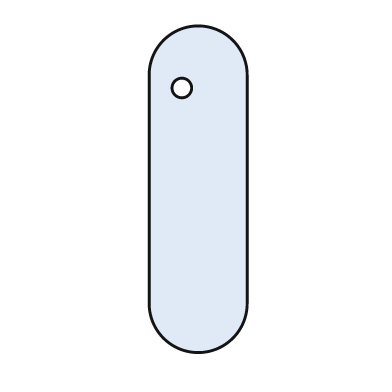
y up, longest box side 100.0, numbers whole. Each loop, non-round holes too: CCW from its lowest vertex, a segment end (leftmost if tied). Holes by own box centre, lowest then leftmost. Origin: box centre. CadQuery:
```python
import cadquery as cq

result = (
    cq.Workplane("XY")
    .moveTo(-15.0, -35.0)
    .threePointArc((0.0, -50.0), (15.0, -35.0))
    .lineTo(15.0, 35.0)
    .threePointArc((0.0, 50.0), (-15.0, 35.0))
    .close()
    .moveTo(-5.0, 31.0)
    .circle(3.0)
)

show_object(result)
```